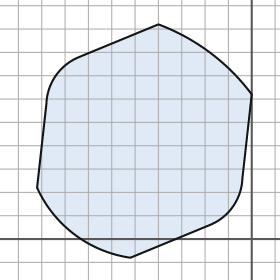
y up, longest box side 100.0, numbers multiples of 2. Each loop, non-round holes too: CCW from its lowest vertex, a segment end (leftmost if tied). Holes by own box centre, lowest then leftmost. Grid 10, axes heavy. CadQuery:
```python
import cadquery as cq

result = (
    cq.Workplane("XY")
    .moveTo(-52.0, -8.0)
    .lineTo(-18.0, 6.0)
    .threePointArc((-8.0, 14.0), (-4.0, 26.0))
    .lineTo(0.0, 62.0)
    .threePointArc((-18.0, 80.0), (-40.0, 92.0))
    .lineTo(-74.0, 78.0)
    .threePointArc((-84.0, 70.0), (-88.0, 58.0))
    .lineTo(-92.0, 22.0)
    .threePointArc((-76.0, 2.0), (-52.0, -8.0))
    .close()
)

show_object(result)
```